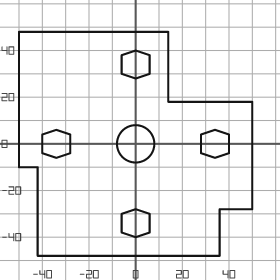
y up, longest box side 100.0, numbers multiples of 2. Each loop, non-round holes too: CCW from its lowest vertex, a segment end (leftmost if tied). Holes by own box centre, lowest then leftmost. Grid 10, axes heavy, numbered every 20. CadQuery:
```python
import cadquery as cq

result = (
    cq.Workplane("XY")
    .moveTo(-42.0, -48.0)
    .lineTo(36.0, -48.0)
    .lineTo(36.0, -28.0)
    .lineTo(50.0, -28.0)
    .lineTo(50.0, 18.0)
    .lineTo(14.0, 18.0)
    .lineTo(14.0, 48.0)
    .lineTo(-50.0, 48.0)
    .lineTo(-50.0, -10.0)
    .lineTo(-42.0, -10.0)
    .close()
    .moveTo(0.0, -40.0)
    .lineTo(6.0, -38.0)
    .lineTo(6.0, -30.0)
    .lineTo(0.0, -28.0)
    .lineTo(-6.0, -30.0)
    .lineTo(-6.0, -38.0)
    .close()
    .moveTo(-34.0, -6.0)
    .lineTo(-28.0, -4.0)
    .lineTo(-28.0, 4.0)
    .lineTo(-34.0, 6.0)
    .lineTo(-40.0, 4.0)
    .lineTo(-40.0, -4.0)
    .close()
    .moveTo(0.0, 0.0)
    .circle(8.0)
    .moveTo(34.0, -6.0)
    .lineTo(40.0, -4.0)
    .lineTo(40.0, 4.0)
    .lineTo(34.0, 6.0)
    .lineTo(28.0, 4.0)
    .lineTo(28.0, -4.0)
    .close()
    .moveTo(0.0, 28.0)
    .lineTo(6.0, 30.0)
    .lineTo(6.0, 38.0)
    .lineTo(0.0, 40.0)
    .lineTo(-6.0, 38.0)
    .lineTo(-6.0, 30.0)
    .close()
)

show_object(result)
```